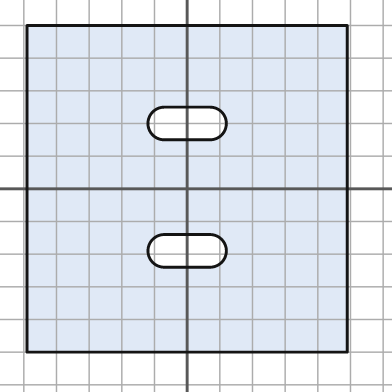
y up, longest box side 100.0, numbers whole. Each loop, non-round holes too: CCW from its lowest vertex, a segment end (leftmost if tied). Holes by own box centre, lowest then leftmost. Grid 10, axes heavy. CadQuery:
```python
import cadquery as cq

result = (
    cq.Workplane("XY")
    .moveTo(-49.0, -50.0)
    .lineTo(49.0, -50.0)
    .lineTo(49.0, 50.0)
    .lineTo(-49.0, 50.0)
    .close()
    .moveTo(-7.0, -24.0)
    .lineTo(7.0, -24.0)
    .threePointArc((12.0, -19.0), (7.0, -14.0))
    .lineTo(-7.0, -14.0)
    .threePointArc((-12.0, -19.0), (-7.0, -24.0))
    .close()
    .moveTo(-7.0, 15.0)
    .lineTo(7.0, 15.0)
    .threePointArc((12.0, 20.0), (7.0, 25.0))
    .lineTo(-7.0, 25.0)
    .threePointArc((-12.0, 20.0), (-7.0, 15.0))
    .close()
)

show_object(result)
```